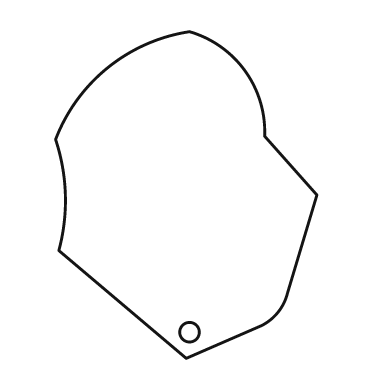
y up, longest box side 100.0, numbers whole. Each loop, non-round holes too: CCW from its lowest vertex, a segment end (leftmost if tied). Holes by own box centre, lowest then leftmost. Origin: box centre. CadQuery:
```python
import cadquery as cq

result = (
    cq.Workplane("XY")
    .moveTo(0.0, -50.0)
    .lineTo(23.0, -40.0)
    .threePointArc((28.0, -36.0), (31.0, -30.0))
    .lineTo(40.0, 0.0)
    .lineTo(24.0, 18.0)
    .threePointArc((18.0, 38.0), (1.0, 50.0))
    .threePointArc((-24.0, 39.0), (-40.0, 17.0))
    .threePointArc((-37.0, 0.0), (-39.0, -17.0))
    .close()
    .moveTo(1.0, -42.0)
    .circle(3.0)
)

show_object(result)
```